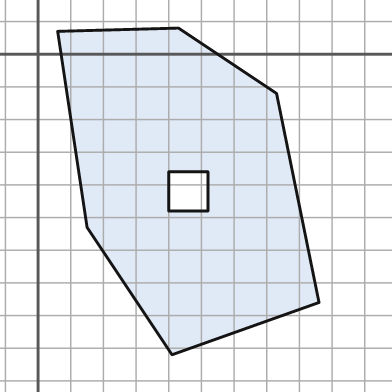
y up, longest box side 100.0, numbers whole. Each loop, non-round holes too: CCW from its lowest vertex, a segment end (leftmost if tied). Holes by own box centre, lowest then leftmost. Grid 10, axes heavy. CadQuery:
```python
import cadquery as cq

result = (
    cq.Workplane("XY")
    .moveTo(41.0, -92.0)
    .lineTo(86.0, -76.0)
    .lineTo(73.0, -12.0)
    .lineTo(43.0, 8.0)
    .lineTo(6.0, 7.0)
    .lineTo(15.0, -53.0)
    .close()
    .moveTo(40.0, -48.0)
    .lineTo(52.0, -48.0)
    .lineTo(52.0, -36.0)
    .lineTo(40.0, -36.0)
    .close()
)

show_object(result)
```